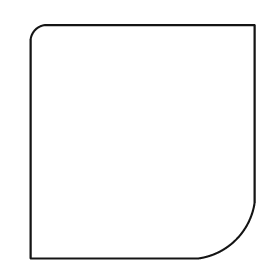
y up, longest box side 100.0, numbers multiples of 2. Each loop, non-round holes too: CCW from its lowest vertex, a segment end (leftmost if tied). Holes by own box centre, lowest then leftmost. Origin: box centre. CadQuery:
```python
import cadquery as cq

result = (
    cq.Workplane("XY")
    .moveTo(-48.0, -50.0)
    .lineTo(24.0, -50.0)
    .threePointArc((40.0, -42.0), (48.0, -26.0))
    .lineTo(48.0, 50.0)
    .lineTo(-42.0, 50.0)
    .threePointArc((-46.0, 48.0), (-48.0, 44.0))
    .close()
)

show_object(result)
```